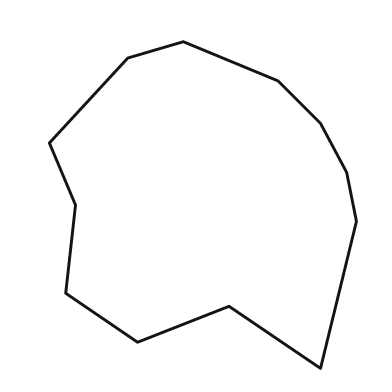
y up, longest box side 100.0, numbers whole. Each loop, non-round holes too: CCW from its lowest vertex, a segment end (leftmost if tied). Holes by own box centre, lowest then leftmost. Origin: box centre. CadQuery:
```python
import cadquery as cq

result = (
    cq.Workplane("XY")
    .moveTo(36.0, -50.0)
    .lineTo(47.0, -5.0)
    .lineTo(44.0, 10.0)
    .lineTo(36.0, 25.0)
    .lineTo(23.0, 38.0)
    .lineTo(-6.0, 50.0)
    .lineTo(-23.0, 45.0)
    .lineTo(-47.0, 19.0)
    .lineTo(-39.0, 0.0)
    .lineTo(-42.0, -27.0)
    .lineTo(-20.0, -42.0)
    .lineTo(8.0, -31.0)
    .close()
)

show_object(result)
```